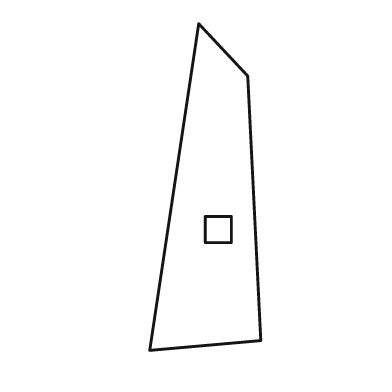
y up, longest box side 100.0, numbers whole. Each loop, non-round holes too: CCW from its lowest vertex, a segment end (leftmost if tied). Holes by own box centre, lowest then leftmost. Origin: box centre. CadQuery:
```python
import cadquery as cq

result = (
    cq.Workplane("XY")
    .moveTo(-17.0, -50.0)
    .lineTo(17.0, -47.0)
    .lineTo(13.0, 34.0)
    .lineTo(-2.0, 50.0)
    .close()
    .moveTo(0.0, -17.0)
    .lineTo(8.0, -17.0)
    .lineTo(8.0, -9.0)
    .lineTo(0.0, -9.0)
    .close()
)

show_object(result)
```